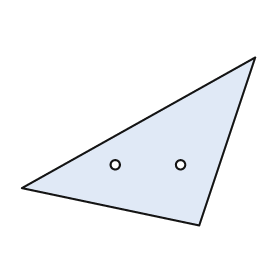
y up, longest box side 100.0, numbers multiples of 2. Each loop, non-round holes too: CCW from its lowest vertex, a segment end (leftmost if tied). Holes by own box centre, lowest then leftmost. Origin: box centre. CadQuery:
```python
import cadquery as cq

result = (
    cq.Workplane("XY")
    .moveTo(26.0, -36.0)
    .lineTo(50.0, 36.0)
    .lineTo(-50.0, -20.0)
    .close()
    .moveTo(-10.0, -10.0)
    .circle(2.0)
    .moveTo(18.0, -10.0)
    .circle(2.0)
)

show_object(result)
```